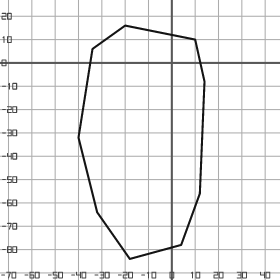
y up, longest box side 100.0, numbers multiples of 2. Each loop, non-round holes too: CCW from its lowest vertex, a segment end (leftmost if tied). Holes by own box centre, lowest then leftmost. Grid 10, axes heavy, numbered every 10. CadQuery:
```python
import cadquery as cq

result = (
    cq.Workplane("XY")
    .moveTo(-18.0, -84.0)
    .lineTo(4.0, -78.0)
    .lineTo(12.0, -56.0)
    .lineTo(14.0, -8.0)
    .lineTo(10.0, 10.0)
    .lineTo(-20.0, 16.0)
    .lineTo(-34.0, 6.0)
    .lineTo(-40.0, -32.0)
    .lineTo(-32.0, -64.0)
    .close()
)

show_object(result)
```